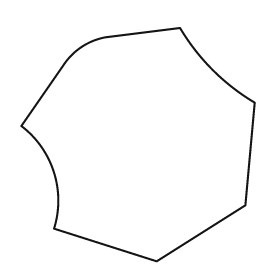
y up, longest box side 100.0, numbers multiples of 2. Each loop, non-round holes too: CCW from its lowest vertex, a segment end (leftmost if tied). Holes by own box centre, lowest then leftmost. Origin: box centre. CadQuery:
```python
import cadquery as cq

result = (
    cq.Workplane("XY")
    .moveTo(8.0, -50.0)
    .lineTo(46.0, -26.0)
    .lineTo(50.0, 18.0)
    .threePointArc((32.0, 32.0), (18.0, 50.0))
    .lineTo(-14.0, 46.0)
    .threePointArc((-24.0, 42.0), (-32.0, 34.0))
    .lineTo(-50.0, 8.0)
    .threePointArc((-36.0, -12.0), (-36.0, -36.0))
    .close()
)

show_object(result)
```